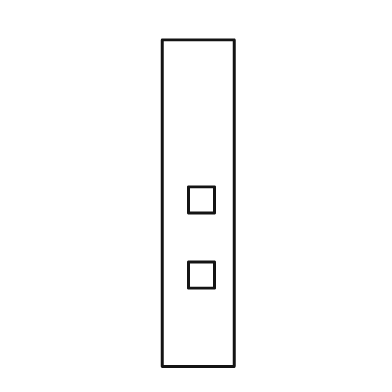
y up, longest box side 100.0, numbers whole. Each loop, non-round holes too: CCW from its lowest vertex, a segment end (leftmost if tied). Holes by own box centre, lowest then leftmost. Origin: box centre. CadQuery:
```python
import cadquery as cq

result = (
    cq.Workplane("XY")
    .moveTo(-11.0, -50.0)
    .lineTo(11.0, -50.0)
    .lineTo(11.0, 50.0)
    .lineTo(-11.0, 50.0)
    .close()
    .moveTo(-3.0, -26.0)
    .lineTo(5.0, -26.0)
    .lineTo(5.0, -18.0)
    .lineTo(-3.0, -18.0)
    .close()
    .moveTo(-3.0, -3.0)
    .lineTo(5.0, -3.0)
    .lineTo(5.0, 5.0)
    .lineTo(-3.0, 5.0)
    .close()
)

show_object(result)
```